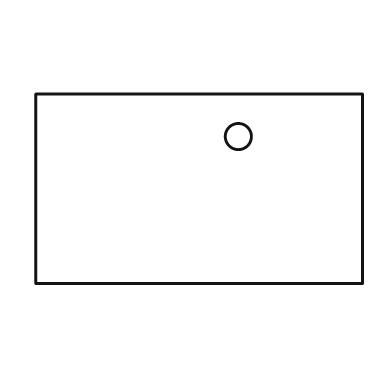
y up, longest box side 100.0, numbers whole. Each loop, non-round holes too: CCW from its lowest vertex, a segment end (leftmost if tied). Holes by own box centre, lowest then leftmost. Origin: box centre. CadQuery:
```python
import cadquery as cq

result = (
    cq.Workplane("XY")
    .moveTo(-50.0, -29.0)
    .lineTo(50.0, -29.0)
    .lineTo(50.0, 29.0)
    .lineTo(-50.0, 29.0)
    .close()
    .moveTo(12.0, 16.0)
    .circle(4.0)
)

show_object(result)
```